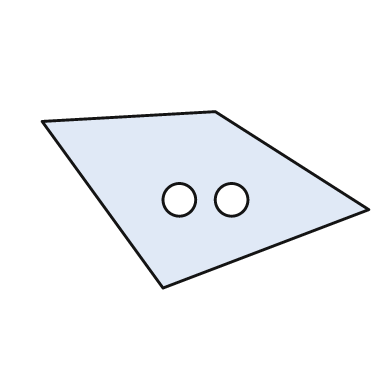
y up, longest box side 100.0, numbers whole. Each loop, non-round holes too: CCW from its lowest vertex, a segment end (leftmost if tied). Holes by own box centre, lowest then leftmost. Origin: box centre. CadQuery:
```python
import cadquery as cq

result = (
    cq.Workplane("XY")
    .moveTo(-13.0, -27.0)
    .lineTo(50.0, -3.0)
    .lineTo(3.0, 27.0)
    .lineTo(-50.0, 24.0)
    .close()
    .moveTo(-8.0, 0.0)
    .circle(5.0)
    .moveTo(8.0, 0.0)
    .circle(5.0)
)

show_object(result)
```